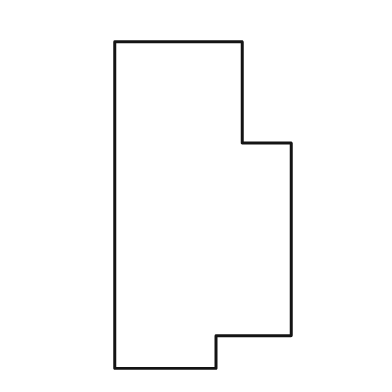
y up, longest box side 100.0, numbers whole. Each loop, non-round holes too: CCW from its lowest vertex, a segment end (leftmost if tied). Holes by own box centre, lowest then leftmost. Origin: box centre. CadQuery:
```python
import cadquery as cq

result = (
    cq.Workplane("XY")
    .moveTo(-27.0, -50.0)
    .lineTo(4.0, -50.0)
    .lineTo(4.0, -40.0)
    .lineTo(27.0, -40.0)
    .lineTo(27.0, 19.0)
    .lineTo(12.0, 19.0)
    .lineTo(12.0, 50.0)
    .lineTo(-27.0, 50.0)
    .close()
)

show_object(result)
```